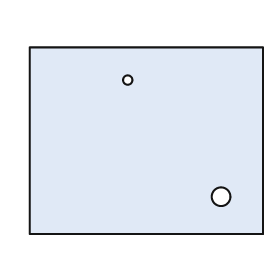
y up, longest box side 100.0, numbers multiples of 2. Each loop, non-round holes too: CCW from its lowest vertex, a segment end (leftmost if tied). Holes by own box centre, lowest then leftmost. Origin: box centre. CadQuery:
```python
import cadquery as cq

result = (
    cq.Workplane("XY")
    .moveTo(-50.0, -40.0)
    .lineTo(50.0, -40.0)
    .lineTo(50.0, 40.0)
    .lineTo(-50.0, 40.0)
    .close()
    .moveTo(32.0, -24.0)
    .circle(4.0)
    .moveTo(-8.0, 26.0)
    .circle(2.0)
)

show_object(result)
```